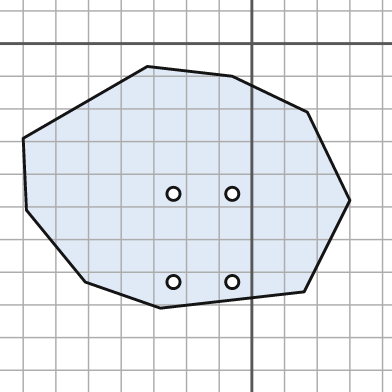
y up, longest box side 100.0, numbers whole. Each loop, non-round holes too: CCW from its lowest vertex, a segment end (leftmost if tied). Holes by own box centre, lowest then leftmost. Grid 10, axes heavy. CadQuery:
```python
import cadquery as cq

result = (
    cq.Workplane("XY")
    .moveTo(-28.0, -81.0)
    .lineTo(16.0, -76.0)
    .lineTo(30.0, -48.0)
    .lineTo(17.0, -21.0)
    .lineTo(-6.0, -10.0)
    .lineTo(-32.0, -7.0)
    .lineTo(-70.0, -29.0)
    .lineTo(-69.0, -51.0)
    .lineTo(-51.0, -73.0)
    .close()
    .moveTo(-24.0, -73.0)
    .circle(2.0)
    .moveTo(-6.0, -73.0)
    .circle(2.0)
    .moveTo(-24.0, -46.0)
    .circle(2.0)
    .moveTo(-6.0, -46.0)
    .circle(2.0)
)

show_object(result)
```